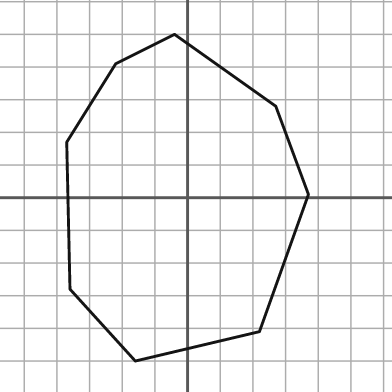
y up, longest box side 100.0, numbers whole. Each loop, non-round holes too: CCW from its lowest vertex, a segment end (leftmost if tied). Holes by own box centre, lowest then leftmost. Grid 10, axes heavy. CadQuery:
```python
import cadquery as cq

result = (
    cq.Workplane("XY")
    .moveTo(-16.0, -50.0)
    .lineTo(22.0, -41.0)
    .lineTo(37.0, 1.0)
    .lineTo(27.0, 28.0)
    .lineTo(-4.0, 50.0)
    .lineTo(-22.0, 41.0)
    .lineTo(-37.0, 17.0)
    .lineTo(-36.0, -28.0)
    .close()
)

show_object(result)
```